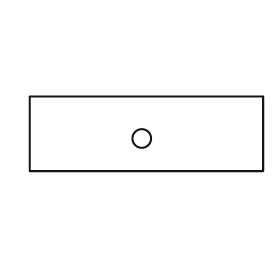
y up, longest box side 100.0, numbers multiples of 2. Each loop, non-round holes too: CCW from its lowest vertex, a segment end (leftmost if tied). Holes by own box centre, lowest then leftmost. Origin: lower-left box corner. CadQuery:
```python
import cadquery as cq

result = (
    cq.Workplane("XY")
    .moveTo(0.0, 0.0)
    .lineTo(100.0, 0.0)
    .lineTo(100.0, 32.0)
    .lineTo(0.0, 32.0)
    .close()
    .moveTo(48.0, 14.0)
    .circle(4.0)
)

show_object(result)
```